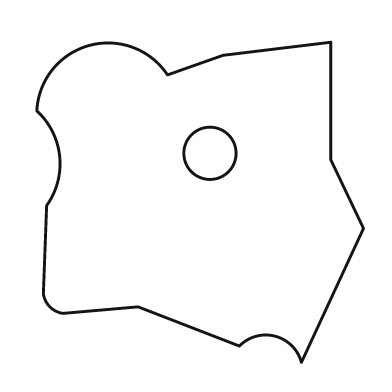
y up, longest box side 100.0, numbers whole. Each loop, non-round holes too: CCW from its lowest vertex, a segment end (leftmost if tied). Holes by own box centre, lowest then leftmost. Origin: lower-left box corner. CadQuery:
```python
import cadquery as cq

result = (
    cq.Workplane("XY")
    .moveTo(81.0, 0.0)
    .lineTo(100.0, 41.0)
    .lineTo(90.0, 62.0)
    .lineTo(90.0, 98.0)
    .lineTo(57.0, 94.0)
    .lineTo(40.0, 88.0)
    .threePointArc((16.0, 97.0), (0.0, 77.0))
    .threePointArc((7.0, 63.0), (3.0, 48.0))
    .lineTo(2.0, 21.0)
    .threePointArc((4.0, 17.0), (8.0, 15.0))
    .lineTo(31.0, 17.0)
    .lineTo(62.0, 5.0)
    .threePointArc((73.0, 8.0), (81.0, 0.0))
    .close()
    .moveTo(53.0, 64.0)
    .circle(8.0)
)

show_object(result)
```